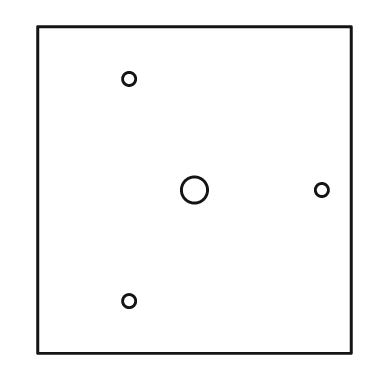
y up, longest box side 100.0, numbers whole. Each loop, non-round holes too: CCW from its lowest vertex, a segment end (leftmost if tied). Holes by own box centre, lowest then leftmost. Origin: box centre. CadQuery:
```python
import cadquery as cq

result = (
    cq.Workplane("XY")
    .moveTo(-48.0, -50.0)
    .lineTo(48.0, -50.0)
    .lineTo(48.0, 50.0)
    .lineTo(-48.0, 50.0)
    .close()
    .moveTo(-20.0, -34.0)
    .circle(2.0)
    .moveTo(0.0, 0.0)
    .circle(4.0)
    .moveTo(39.0, 0.0)
    .circle(2.0)
    .moveTo(-20.0, 34.0)
    .circle(2.0)
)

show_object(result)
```